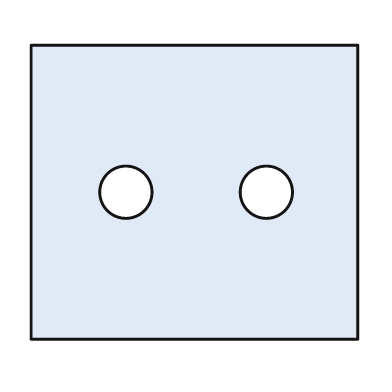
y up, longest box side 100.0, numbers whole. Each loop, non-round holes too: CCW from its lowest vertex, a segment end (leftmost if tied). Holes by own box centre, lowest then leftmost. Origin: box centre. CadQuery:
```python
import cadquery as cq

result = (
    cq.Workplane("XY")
    .moveTo(-50.0, -45.0)
    .lineTo(50.0, -45.0)
    .lineTo(50.0, 45.0)
    .lineTo(-50.0, 45.0)
    .close()
    .moveTo(-21.0, 0.0)
    .circle(8.0)
    .moveTo(22.0, 0.0)
    .circle(8.0)
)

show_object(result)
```